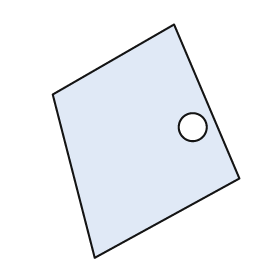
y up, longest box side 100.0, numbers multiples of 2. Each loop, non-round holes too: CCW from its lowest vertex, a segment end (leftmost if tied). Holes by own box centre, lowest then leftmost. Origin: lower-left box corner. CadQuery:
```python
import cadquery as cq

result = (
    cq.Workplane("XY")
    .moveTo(18.0, 0.0)
    .lineTo(80.0, 34.0)
    .lineTo(52.0, 100.0)
    .lineTo(0.0, 70.0)
    .close()
    .moveTo(60.0, 56.0)
    .circle(6.0)
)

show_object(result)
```